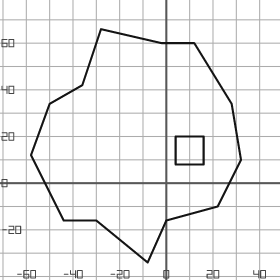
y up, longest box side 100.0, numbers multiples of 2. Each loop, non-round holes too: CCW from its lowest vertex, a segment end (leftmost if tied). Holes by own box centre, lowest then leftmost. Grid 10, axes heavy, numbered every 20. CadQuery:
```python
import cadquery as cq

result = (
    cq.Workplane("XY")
    .moveTo(-8.0, -34.0)
    .lineTo(0.0, -16.0)
    .lineTo(22.0, -10.0)
    .lineTo(32.0, 10.0)
    .lineTo(28.0, 34.0)
    .lineTo(12.0, 60.0)
    .lineTo(-2.0, 60.0)
    .lineTo(-28.0, 66.0)
    .lineTo(-36.0, 42.0)
    .lineTo(-50.0, 34.0)
    .lineTo(-58.0, 12.0)
    .lineTo(-44.0, -16.0)
    .lineTo(-30.0, -16.0)
    .close()
    .moveTo(4.0, 8.0)
    .lineTo(16.0, 8.0)
    .lineTo(16.0, 20.0)
    .lineTo(4.0, 20.0)
    .close()
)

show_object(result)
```